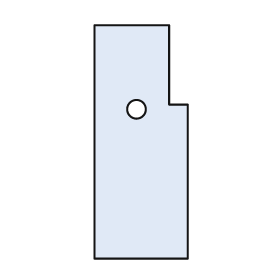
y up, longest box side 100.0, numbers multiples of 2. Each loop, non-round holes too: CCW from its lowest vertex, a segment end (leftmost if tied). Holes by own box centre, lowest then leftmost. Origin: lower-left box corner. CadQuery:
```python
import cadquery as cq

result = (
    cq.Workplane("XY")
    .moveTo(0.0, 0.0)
    .lineTo(40.0, 0.0)
    .lineTo(40.0, 66.0)
    .lineTo(32.0, 66.0)
    .lineTo(32.0, 100.0)
    .lineTo(0.0, 100.0)
    .close()
    .moveTo(18.0, 64.0)
    .circle(4.0)
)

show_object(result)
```